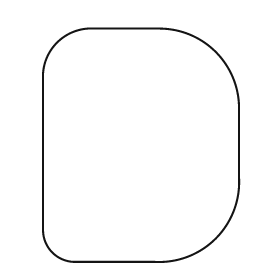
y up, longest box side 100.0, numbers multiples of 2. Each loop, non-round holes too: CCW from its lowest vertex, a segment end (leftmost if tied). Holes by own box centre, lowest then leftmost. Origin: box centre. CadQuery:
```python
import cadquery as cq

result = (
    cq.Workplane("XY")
    .moveTo(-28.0, -50.0)
    .lineTo(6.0, -50.0)
    .threePointArc((32.0, -40.0), (42.0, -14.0))
    .lineTo(42.0, 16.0)
    .threePointArc((32.0, 40.0), (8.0, 50.0))
    .lineTo(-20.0, 50.0)
    .threePointArc((-36.0, 44.0), (-42.0, 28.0))
    .lineTo(-42.0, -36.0)
    .threePointArc((-38.0, -46.0), (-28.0, -50.0))
    .close()
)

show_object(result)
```